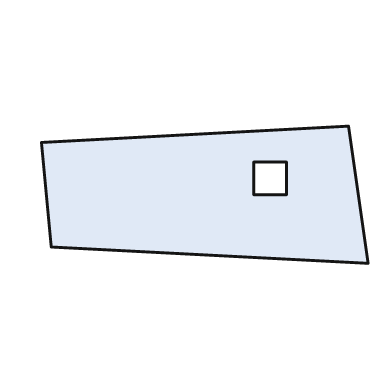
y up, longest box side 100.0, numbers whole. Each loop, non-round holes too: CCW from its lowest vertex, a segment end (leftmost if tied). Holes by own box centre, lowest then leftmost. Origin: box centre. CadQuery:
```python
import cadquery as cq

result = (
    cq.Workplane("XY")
    .moveTo(50.0, -21.0)
    .lineTo(44.0, 21.0)
    .lineTo(-50.0, 16.0)
    .lineTo(-47.0, -16.0)
    .close()
    .moveTo(15.0, 0.0)
    .lineTo(25.0, 0.0)
    .lineTo(25.0, 10.0)
    .lineTo(15.0, 10.0)
    .close()
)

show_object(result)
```